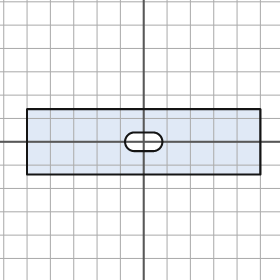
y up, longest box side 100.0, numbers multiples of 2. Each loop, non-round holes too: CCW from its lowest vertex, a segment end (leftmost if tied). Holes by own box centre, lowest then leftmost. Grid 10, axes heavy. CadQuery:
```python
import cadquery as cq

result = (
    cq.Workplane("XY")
    .moveTo(-50.0, -14.0)
    .lineTo(50.0, -14.0)
    .lineTo(50.0, 14.0)
    .lineTo(-50.0, 14.0)
    .close()
    .moveTo(-4.0, -4.0)
    .lineTo(4.0, -4.0)
    .threePointArc((8.0, 0.0), (4.0, 4.0))
    .lineTo(-4.0, 4.0)
    .threePointArc((-8.0, 0.0), (-4.0, -4.0))
    .close()
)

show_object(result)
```